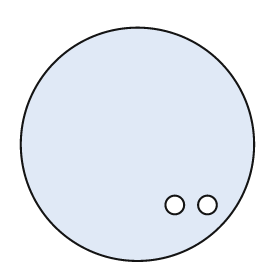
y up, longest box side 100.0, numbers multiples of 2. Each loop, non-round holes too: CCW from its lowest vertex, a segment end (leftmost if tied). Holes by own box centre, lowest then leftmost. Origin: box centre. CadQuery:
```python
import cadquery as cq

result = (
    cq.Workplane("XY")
    .moveTo(0.0, 0.0)
    .circle(50.0)
    .moveTo(16.0, -26.0)
    .circle(4.0)
    .moveTo(30.0, -26.0)
    .circle(4.0)
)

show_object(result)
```